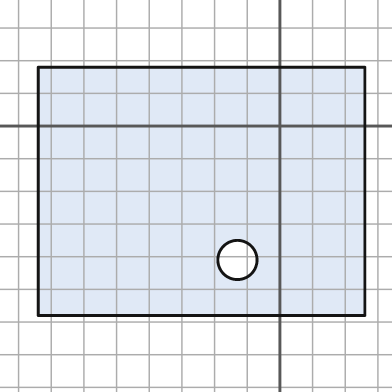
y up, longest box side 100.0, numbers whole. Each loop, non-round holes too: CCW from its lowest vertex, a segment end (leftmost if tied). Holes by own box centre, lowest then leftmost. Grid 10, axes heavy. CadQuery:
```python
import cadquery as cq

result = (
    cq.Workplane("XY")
    .moveTo(-74.0, -58.0)
    .lineTo(26.0, -58.0)
    .lineTo(26.0, 18.0)
    .lineTo(-74.0, 18.0)
    .close()
    .moveTo(-13.0, -41.0)
    .circle(6.0)
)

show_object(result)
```